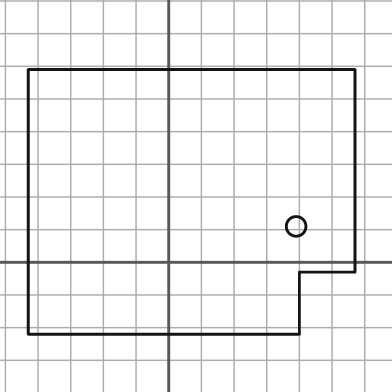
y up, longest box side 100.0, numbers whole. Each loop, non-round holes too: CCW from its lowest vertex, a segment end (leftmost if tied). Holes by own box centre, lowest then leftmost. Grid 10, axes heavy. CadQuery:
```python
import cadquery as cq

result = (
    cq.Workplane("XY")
    .moveTo(-43.0, -22.0)
    .lineTo(40.0, -22.0)
    .lineTo(40.0, -3.0)
    .lineTo(57.0, -3.0)
    .lineTo(57.0, 59.0)
    .lineTo(-43.0, 59.0)
    .close()
    .moveTo(39.0, 11.0)
    .circle(3.0)
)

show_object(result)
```